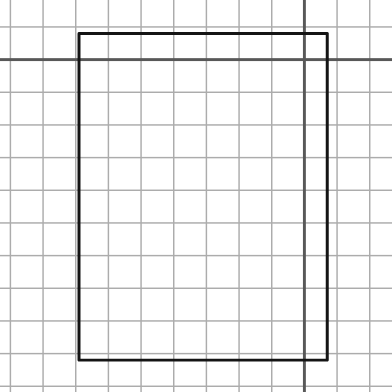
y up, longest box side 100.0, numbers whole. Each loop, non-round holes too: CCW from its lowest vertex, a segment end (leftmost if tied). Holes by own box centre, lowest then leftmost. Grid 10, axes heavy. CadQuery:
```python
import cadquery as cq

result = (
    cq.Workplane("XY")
    .moveTo(-69.0, -92.0)
    .lineTo(7.0, -92.0)
    .lineTo(7.0, 8.0)
    .lineTo(-69.0, 8.0)
    .close()
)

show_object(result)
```